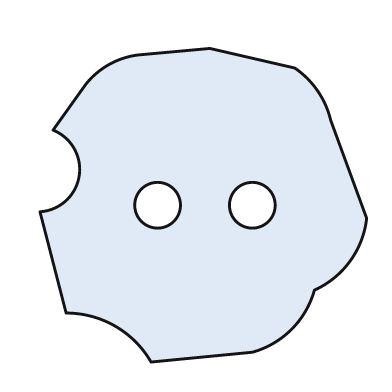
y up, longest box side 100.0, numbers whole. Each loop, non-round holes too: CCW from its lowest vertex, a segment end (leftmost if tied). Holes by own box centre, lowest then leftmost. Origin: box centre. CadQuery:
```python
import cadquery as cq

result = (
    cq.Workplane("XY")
    .moveTo(-16.0, -48.0)
    .lineTo(15.0, -45.0)
    .threePointArc((27.0, -38.0), (34.0, -26.0))
    .threePointArc((45.0, -17.0), (50.0, -4.0))
    .lineTo(39.0, 26.0)
    .threePointArc((35.0, 35.0), (28.0, 42.0))
    .lineTo(2.0, 48.0)
    .lineTo(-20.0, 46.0)
    .threePointArc((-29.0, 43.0), (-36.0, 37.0))
    .lineTo(-46.0, 23.0)
    .threePointArc((-38.0, 9.0), (-50.0, -2.0))
    .lineTo(-42.0, -33.0)
    .threePointArc((-27.0, -37.0), (-16.0, -48.0))
    .close()
    .moveTo(-14.0, 0.0)
    .circle(7.0)
    .moveTo(15.0, 0.0)
    .circle(7.0)
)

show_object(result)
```